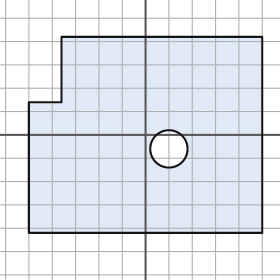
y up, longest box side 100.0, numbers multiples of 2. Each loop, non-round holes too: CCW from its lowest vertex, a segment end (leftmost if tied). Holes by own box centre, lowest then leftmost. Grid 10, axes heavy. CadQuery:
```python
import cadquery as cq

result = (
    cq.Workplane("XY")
    .moveTo(-50.0, -42.0)
    .lineTo(50.0, -42.0)
    .lineTo(50.0, 42.0)
    .lineTo(-36.0, 42.0)
    .lineTo(-36.0, 14.0)
    .lineTo(-50.0, 14.0)
    .close()
    .moveTo(10.0, -6.0)
    .circle(8.0)
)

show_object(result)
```